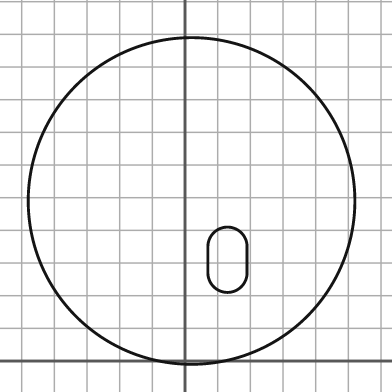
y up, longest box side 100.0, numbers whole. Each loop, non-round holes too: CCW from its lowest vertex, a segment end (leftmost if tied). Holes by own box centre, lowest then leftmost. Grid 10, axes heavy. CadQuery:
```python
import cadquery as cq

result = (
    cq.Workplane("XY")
    .moveTo(2.0, 49.0)
    .circle(50.0)
    .moveTo(7.0, 27.0)
    .threePointArc((13.0, 21.0), (19.0, 27.0))
    .lineTo(19.0, 35.0)
    .threePointArc((13.0, 41.0), (7.0, 35.0))
    .close()
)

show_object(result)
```